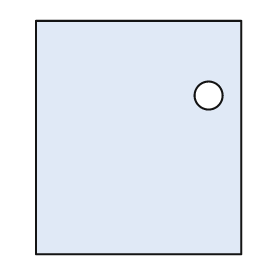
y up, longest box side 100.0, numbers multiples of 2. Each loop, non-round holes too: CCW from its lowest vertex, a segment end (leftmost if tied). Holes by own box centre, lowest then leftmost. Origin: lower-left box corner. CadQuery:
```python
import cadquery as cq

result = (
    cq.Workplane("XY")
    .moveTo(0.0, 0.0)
    .lineTo(88.0, 0.0)
    .lineTo(88.0, 100.0)
    .lineTo(0.0, 100.0)
    .close()
    .moveTo(74.0, 68.0)
    .circle(6.0)
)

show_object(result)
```